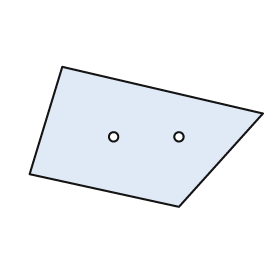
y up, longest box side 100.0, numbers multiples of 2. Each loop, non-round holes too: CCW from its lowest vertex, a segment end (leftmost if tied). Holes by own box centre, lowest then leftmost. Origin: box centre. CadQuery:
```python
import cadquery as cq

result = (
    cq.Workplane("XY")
    .moveTo(14.0, -30.0)
    .lineTo(50.0, 10.0)
    .lineTo(-36.0, 30.0)
    .lineTo(-50.0, -16.0)
    .close()
    .moveTo(-14.0, 0.0)
    .circle(2.0)
    .moveTo(14.0, 0.0)
    .circle(2.0)
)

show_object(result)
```